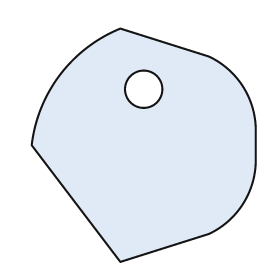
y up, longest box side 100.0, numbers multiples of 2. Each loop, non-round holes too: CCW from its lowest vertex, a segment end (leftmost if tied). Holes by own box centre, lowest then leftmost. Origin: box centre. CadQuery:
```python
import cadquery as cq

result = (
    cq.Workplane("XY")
    .moveTo(-10.0, -50.0)
    .lineTo(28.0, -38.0)
    .threePointArc((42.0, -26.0), (48.0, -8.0))
    .lineTo(48.0, 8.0)
    .threePointArc((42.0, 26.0), (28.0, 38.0))
    .lineTo(-10.0, 50.0)
    .threePointArc((-36.0, 30.0), (-48.0, 0.0))
    .close()
    .moveTo(0.0, 24.0)
    .circle(8.0)
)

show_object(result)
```